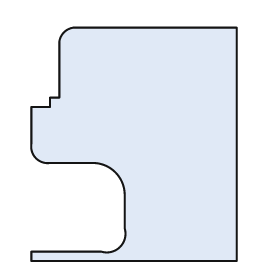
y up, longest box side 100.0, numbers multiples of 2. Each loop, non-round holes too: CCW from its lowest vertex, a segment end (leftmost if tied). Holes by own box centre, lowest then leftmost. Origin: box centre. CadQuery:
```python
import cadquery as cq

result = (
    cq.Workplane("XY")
    .moveTo(-44.0, -50.0)
    .lineTo(44.0, -50.0)
    .lineTo(44.0, 50.0)
    .lineTo(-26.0, 50.0)
    .threePointArc((-30.0, 48.0), (-32.0, 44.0))
    .lineTo(-32.0, 20.0)
    .lineTo(-36.0, 20.0)
    .lineTo(-36.0, 16.0)
    .lineTo(-44.0, 16.0)
    .lineTo(-44.0, 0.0)
    .threePointArc((-42.0, -6.0), (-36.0, -8.0))
    .lineTo(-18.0, -8.0)
    .threePointArc((-8.0, -12.0), (-4.0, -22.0))
    .lineTo(-4.0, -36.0)
    .threePointArc((-6.0, -44.0), (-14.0, -46.0))
    .lineTo(-44.0, -46.0)
    .close()
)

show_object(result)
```